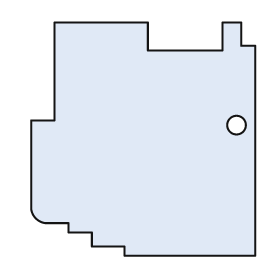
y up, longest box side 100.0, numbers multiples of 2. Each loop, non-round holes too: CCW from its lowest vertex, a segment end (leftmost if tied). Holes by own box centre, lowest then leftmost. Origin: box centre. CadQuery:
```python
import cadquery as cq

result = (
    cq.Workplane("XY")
    .moveTo(-8.0, -50.0)
    .lineTo(48.0, -50.0)
    .lineTo(48.0, 40.0)
    .lineTo(42.0, 40.0)
    .lineTo(42.0, 50.0)
    .lineTo(34.0, 50.0)
    .lineTo(34.0, 38.0)
    .lineTo(2.0, 38.0)
    .lineTo(2.0, 50.0)
    .lineTo(-38.0, 50.0)
    .lineTo(-38.0, 8.0)
    .lineTo(-48.0, 8.0)
    .lineTo(-48.0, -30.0)
    .threePointArc((-46.0, -34.0), (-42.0, -36.0))
    .lineTo(-32.0, -36.0)
    .lineTo(-32.0, -40.0)
    .lineTo(-22.0, -40.0)
    .lineTo(-22.0, -46.0)
    .lineTo(-8.0, -46.0)
    .close()
    .moveTo(40.0, 6.0)
    .circle(4.0)
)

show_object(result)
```